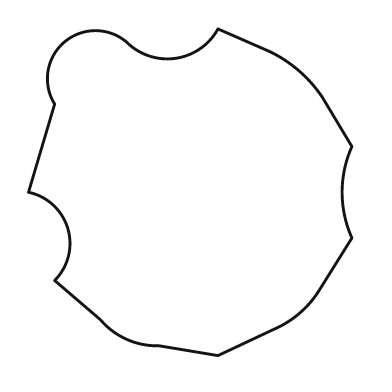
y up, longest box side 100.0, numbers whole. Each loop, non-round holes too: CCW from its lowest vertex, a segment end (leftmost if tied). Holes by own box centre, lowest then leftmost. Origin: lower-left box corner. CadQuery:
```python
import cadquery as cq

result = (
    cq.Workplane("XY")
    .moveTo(58.0, 0.0)
    .lineTo(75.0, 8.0)
    .threePointArc((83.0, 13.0), (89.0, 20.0))
    .lineTo(99.0, 36.0)
    .threePointArc((96.0, 50.0), (99.0, 64.0))
    .lineTo(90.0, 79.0)
    .threePointArc((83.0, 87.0), (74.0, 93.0))
    .lineTo(58.0, 100.0)
    .threePointArc((45.0, 91.0), (30.0, 96.0))
    .threePointArc((11.0, 96.0), (8.0, 77.0))
    .lineTo(0.0, 50.0)
    .threePointArc((12.0, 39.0), (8.0, 23.0))
    .lineTo(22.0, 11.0)
    .threePointArc((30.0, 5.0), (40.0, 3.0))
    .close()
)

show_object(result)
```